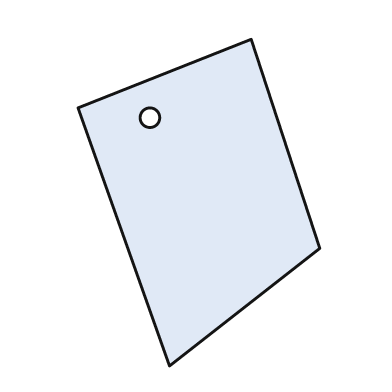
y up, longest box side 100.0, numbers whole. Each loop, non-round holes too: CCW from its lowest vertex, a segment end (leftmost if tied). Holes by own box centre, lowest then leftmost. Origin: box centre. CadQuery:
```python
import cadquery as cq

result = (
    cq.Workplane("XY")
    .moveTo(-9.0, -50.0)
    .lineTo(37.0, -14.0)
    .lineTo(16.0, 50.0)
    .lineTo(-37.0, 29.0)
    .close()
    .moveTo(-15.0, 26.0)
    .circle(3.0)
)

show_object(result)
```